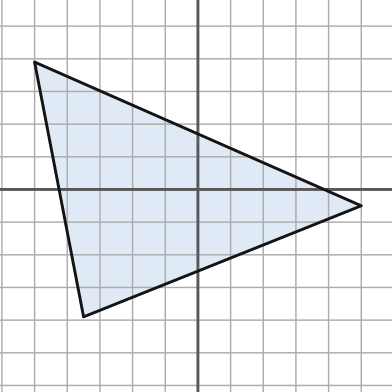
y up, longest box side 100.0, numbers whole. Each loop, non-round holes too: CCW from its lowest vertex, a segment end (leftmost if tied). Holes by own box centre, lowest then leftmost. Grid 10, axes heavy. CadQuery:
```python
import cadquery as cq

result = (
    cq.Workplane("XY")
    .moveTo(-35.0, -39.0)
    .lineTo(50.0, -5.0)
    .lineTo(-50.0, 39.0)
    .close()
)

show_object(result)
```